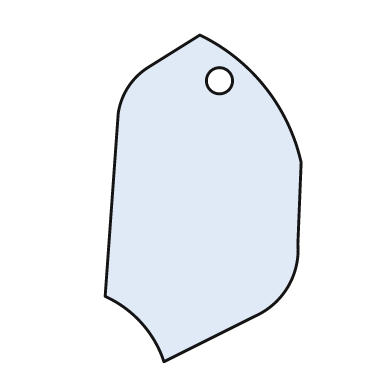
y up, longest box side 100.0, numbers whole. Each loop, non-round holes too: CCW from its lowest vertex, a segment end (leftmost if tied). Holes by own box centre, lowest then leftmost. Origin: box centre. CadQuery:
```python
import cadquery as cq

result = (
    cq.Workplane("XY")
    .moveTo(-12.0, -50.0)
    .lineTo(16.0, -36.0)
    .threePointArc((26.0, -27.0), (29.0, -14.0))
    .lineTo(30.0, 11.0)
    .threePointArc((19.0, 34.0), (-1.0, 50.0))
    .lineTo(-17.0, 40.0)
    .threePointArc((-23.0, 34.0), (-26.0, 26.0))
    .lineTo(-30.0, -30.0)
    .threePointArc((-19.0, -38.0), (-12.0, -50.0))
    .close()
    .moveTo(5.0, 36.0)
    .circle(4.0)
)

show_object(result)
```